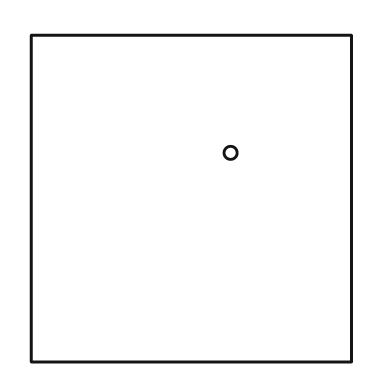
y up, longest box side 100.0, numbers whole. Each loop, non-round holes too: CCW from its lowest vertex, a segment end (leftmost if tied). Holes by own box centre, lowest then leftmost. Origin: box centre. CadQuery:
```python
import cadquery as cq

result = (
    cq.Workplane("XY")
    .moveTo(-49.0, -50.0)
    .lineTo(49.0, -50.0)
    .lineTo(49.0, 50.0)
    .lineTo(-49.0, 50.0)
    .close()
    .moveTo(12.0, 14.0)
    .circle(2.0)
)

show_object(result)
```